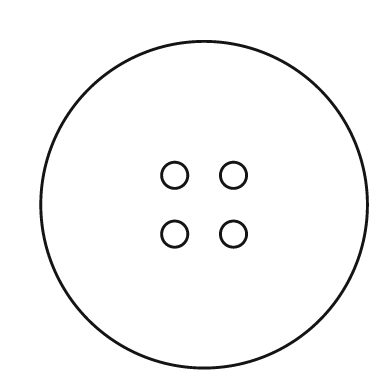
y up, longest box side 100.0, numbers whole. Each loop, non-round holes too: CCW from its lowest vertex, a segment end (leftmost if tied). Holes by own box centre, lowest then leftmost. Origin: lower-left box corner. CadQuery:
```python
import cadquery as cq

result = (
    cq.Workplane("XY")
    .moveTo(50.0, 50.0)
    .circle(50.0)
    .moveTo(41.0, 41.0)
    .circle(4.0)
    .moveTo(59.0, 41.0)
    .circle(4.0)
    .moveTo(41.0, 59.0)
    .circle(4.0)
    .moveTo(59.0, 59.0)
    .circle(4.0)
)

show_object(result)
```